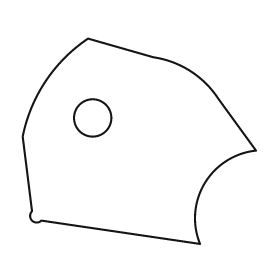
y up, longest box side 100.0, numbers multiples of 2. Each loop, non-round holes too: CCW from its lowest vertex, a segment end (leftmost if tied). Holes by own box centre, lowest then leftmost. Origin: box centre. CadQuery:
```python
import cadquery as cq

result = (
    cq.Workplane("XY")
    .moveTo(26.0, -44.0)
    .threePointArc((28.0, -18.0), (50.0, -4.0))
    .lineTo(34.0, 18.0)
    .threePointArc((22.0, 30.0), (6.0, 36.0))
    .lineTo(-22.0, 44.0)
    .threePointArc((-40.0, 26.0), (-50.0, 2.0))
    .lineTo(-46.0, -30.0)
    .threePointArc((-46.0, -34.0), (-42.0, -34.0))
    .close()
    .moveTo(-20.0, 10.0)
    .circle(8.0)
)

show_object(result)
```